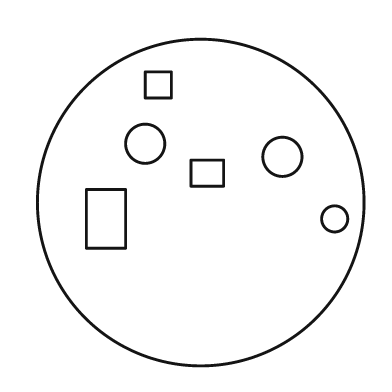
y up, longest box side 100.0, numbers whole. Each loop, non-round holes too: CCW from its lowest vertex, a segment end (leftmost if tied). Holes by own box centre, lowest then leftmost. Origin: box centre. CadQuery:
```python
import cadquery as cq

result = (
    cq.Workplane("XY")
    .moveTo(0.0, 0.0)
    .circle(50.0)
    .moveTo(-35.0, -14.0)
    .lineTo(-23.0, -14.0)
    .lineTo(-23.0, 4.0)
    .lineTo(-35.0, 4.0)
    .close()
    .moveTo(41.0, -5.0)
    .circle(4.0)
    .moveTo(-3.0, 5.0)
    .lineTo(7.0, 5.0)
    .lineTo(7.0, 13.0)
    .lineTo(-3.0, 13.0)
    .close()
    .moveTo(25.0, 14.0)
    .circle(6.0)
    .moveTo(-17.0, 18.0)
    .circle(6.0)
    .moveTo(-17.0, 32.0)
    .lineTo(-9.0, 32.0)
    .lineTo(-9.0, 40.0)
    .lineTo(-17.0, 40.0)
    .close()
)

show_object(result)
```